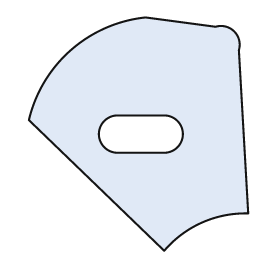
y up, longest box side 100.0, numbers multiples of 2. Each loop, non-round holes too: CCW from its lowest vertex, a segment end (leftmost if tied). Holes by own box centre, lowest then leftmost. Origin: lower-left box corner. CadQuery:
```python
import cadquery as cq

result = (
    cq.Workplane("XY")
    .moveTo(58.0, 0.0)
    .threePointArc((74.0, 12.0), (94.0, 16.0))
    .lineTo(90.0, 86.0)
    .threePointArc((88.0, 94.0), (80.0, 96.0))
    .lineTo(50.0, 100.0)
    .threePointArc((18.0, 86.0), (0.0, 56.0))
    .close()
    .moveTo(38.0, 42.0)
    .lineTo(58.0, 42.0)
    .threePointArc((66.0, 50.0), (58.0, 58.0))
    .lineTo(38.0, 58.0)
    .threePointArc((30.0, 50.0), (38.0, 42.0))
    .close()
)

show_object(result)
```